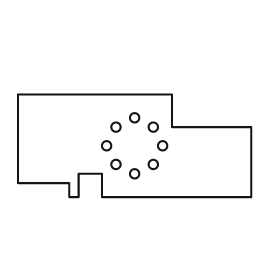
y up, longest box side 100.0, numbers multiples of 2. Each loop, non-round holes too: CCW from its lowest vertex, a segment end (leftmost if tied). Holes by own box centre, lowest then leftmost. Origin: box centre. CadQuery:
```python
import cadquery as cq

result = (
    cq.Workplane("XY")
    .moveTo(-28.0, -22.0)
    .lineTo(-24.0, -22.0)
    .lineTo(-24.0, -12.0)
    .lineTo(-14.0, -12.0)
    .lineTo(-14.0, -22.0)
    .lineTo(50.0, -22.0)
    .lineTo(50.0, 8.0)
    .lineTo(16.0, 8.0)
    .lineTo(16.0, 22.0)
    .lineTo(-50.0, 22.0)
    .lineTo(-50.0, -16.0)
    .lineTo(-28.0, -16.0)
    .close()
    .moveTo(0.0, -12.0)
    .circle(2.0)
    .moveTo(-8.0, -8.0)
    .circle(2.0)
    .moveTo(8.0, -8.0)
    .circle(2.0)
    .moveTo(-12.0, 0.0)
    .circle(2.0)
    .moveTo(12.0, 0.0)
    .circle(2.0)
    .moveTo(-8.0, 8.0)
    .circle(2.0)
    .moveTo(8.0, 8.0)
    .circle(2.0)
    .moveTo(0.0, 12.0)
    .circle(2.0)
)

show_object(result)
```